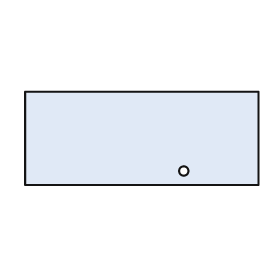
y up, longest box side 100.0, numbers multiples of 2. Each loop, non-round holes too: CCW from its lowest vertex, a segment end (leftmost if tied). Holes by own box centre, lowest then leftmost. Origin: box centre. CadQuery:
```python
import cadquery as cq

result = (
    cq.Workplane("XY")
    .moveTo(-50.0, -20.0)
    .lineTo(50.0, -20.0)
    .lineTo(50.0, 20.0)
    .lineTo(-50.0, 20.0)
    .close()
    .moveTo(18.0, -14.0)
    .circle(2.0)
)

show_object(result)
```